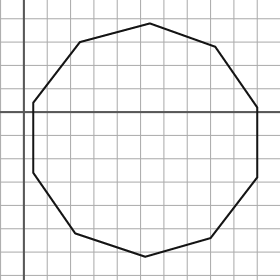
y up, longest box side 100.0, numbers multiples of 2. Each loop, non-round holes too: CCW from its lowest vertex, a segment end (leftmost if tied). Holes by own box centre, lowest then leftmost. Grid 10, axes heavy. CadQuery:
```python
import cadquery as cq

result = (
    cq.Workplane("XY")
    .moveTo(52.0, -62.0)
    .lineTo(80.0, -54.0)
    .lineTo(100.0, -28.0)
    .lineTo(100.0, 2.0)
    .lineTo(82.0, 28.0)
    .lineTo(54.0, 38.0)
    .lineTo(24.0, 30.0)
    .lineTo(4.0, 4.0)
    .lineTo(4.0, -26.0)
    .lineTo(22.0, -52.0)
    .close()
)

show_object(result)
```